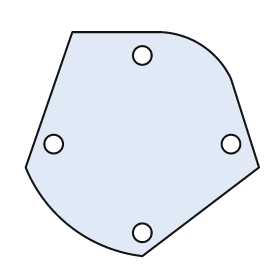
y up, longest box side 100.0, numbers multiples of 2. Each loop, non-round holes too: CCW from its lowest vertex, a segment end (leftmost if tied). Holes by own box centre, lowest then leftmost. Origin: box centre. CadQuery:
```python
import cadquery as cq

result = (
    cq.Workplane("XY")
    .moveTo(0.0, -48.0)
    .lineTo(50.0, -10.0)
    .lineTo(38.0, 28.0)
    .threePointArc((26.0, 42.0), (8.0, 48.0))
    .lineTo(-30.0, 48.0)
    .lineTo(-50.0, -10.0)
    .threePointArc((-30.0, -36.0), (0.0, -48.0))
    .close()
    .moveTo(0.0, -38.0)
    .circle(4.0)
    .moveTo(-38.0, 0.0)
    .circle(4.0)
    .moveTo(38.0, 0.0)
    .circle(4.0)
    .moveTo(0.0, 38.0)
    .circle(4.0)
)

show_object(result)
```